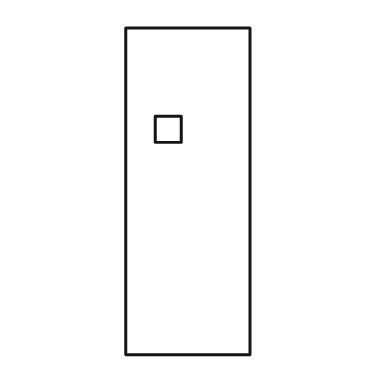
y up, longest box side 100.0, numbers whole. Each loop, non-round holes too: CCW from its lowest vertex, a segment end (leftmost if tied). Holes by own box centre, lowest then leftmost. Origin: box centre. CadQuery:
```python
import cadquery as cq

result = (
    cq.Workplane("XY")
    .moveTo(-19.0, -50.0)
    .lineTo(19.0, -50.0)
    .lineTo(19.0, 50.0)
    .lineTo(-19.0, 50.0)
    .close()
    .moveTo(-10.0, 15.0)
    .lineTo(-2.0, 15.0)
    .lineTo(-2.0, 23.0)
    .lineTo(-10.0, 23.0)
    .close()
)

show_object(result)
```